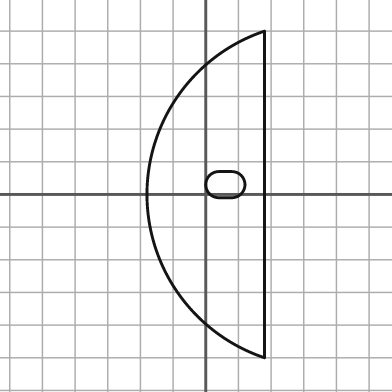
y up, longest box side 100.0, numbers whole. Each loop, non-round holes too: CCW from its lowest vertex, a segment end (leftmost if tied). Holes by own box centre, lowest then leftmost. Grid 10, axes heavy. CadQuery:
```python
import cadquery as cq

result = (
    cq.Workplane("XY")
    .moveTo(18.0, -50.0)
    .lineTo(18.0, 50.0)
    .threePointArc((-18.0, 0.0), (18.0, -50.0))
    .close()
    .moveTo(4.0, -1.0)
    .lineTo(8.0, -1.0)
    .threePointArc((12.0, 3.0), (8.0, 7.0))
    .lineTo(4.0, 7.0)
    .threePointArc((0.0, 3.0), (4.0, -1.0))
    .close()
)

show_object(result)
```